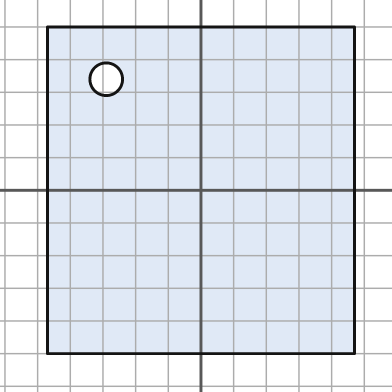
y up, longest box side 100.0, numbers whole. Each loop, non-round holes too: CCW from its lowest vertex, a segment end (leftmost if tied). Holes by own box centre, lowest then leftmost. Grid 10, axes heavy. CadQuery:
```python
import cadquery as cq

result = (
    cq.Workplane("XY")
    .moveTo(-47.0, -50.0)
    .lineTo(47.0, -50.0)
    .lineTo(47.0, 50.0)
    .lineTo(-47.0, 50.0)
    .close()
    .moveTo(-29.0, 34.0)
    .circle(5.0)
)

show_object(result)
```